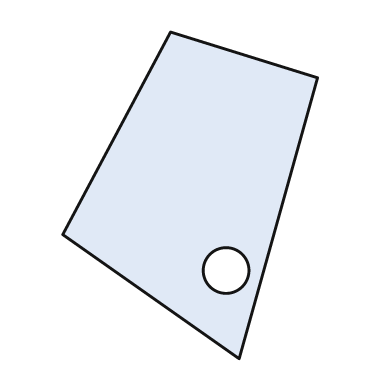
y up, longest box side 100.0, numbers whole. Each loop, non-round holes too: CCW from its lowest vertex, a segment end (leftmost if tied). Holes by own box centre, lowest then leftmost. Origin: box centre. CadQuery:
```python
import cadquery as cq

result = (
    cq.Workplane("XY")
    .moveTo(15.0, -50.0)
    .lineTo(39.0, 36.0)
    .lineTo(-6.0, 50.0)
    .lineTo(-39.0, -12.0)
    .close()
    .moveTo(11.0, -23.0)
    .circle(7.0)
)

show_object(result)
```